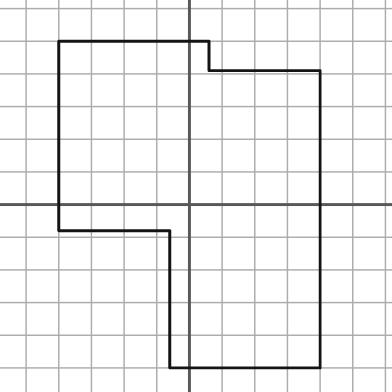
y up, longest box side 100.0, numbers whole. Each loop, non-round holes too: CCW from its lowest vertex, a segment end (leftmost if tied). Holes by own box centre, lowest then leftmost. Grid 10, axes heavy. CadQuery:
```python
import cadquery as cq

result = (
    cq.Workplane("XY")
    .moveTo(-6.0, -50.0)
    .lineTo(40.0, -50.0)
    .lineTo(40.0, 41.0)
    .lineTo(6.0, 41.0)
    .lineTo(6.0, 50.0)
    .lineTo(-40.0, 50.0)
    .lineTo(-40.0, -8.0)
    .lineTo(-6.0, -8.0)
    .close()
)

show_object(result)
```